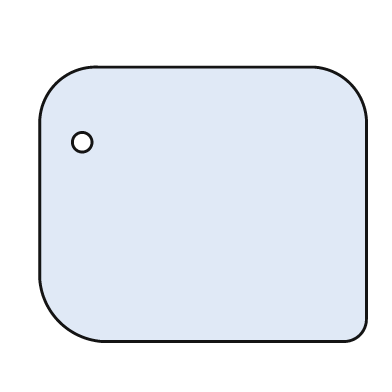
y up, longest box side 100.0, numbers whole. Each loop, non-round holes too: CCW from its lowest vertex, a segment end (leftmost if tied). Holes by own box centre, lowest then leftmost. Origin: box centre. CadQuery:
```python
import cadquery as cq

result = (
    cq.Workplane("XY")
    .moveTo(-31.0, -42.0)
    .lineTo(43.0, -42.0)
    .threePointArc((48.0, -40.0), (50.0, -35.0))
    .lineTo(50.0, 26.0)
    .threePointArc((45.0, 37.0), (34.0, 42.0))
    .lineTo(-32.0, 42.0)
    .threePointArc((-45.0, 37.0), (-50.0, 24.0))
    .lineTo(-50.0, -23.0)
    .threePointArc((-44.0, -36.0), (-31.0, -42.0))
    .close()
    .moveTo(-37.0, 19.0)
    .circle(3.0)
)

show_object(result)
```